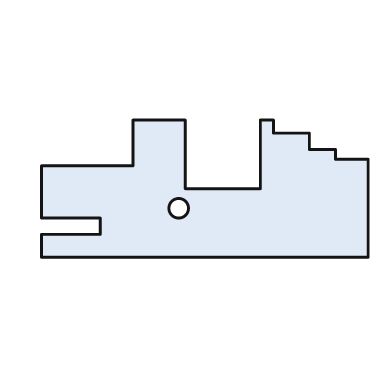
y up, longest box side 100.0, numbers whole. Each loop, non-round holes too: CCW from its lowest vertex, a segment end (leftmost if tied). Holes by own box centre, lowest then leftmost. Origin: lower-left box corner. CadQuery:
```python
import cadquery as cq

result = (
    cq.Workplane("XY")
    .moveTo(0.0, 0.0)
    .lineTo(100.0, 0.0)
    .lineTo(100.0, 30.0)
    .lineTo(90.0, 30.0)
    .lineTo(90.0, 33.0)
    .lineTo(82.0, 33.0)
    .lineTo(82.0, 38.0)
    .lineTo(71.0, 38.0)
    .lineTo(71.0, 42.0)
    .lineTo(67.0, 42.0)
    .lineTo(67.0, 21.0)
    .lineTo(44.0, 21.0)
    .lineTo(44.0, 42.0)
    .lineTo(28.0, 42.0)
    .lineTo(28.0, 28.0)
    .lineTo(0.0, 28.0)
    .lineTo(0.0, 12.0)
    .lineTo(18.0, 12.0)
    .lineTo(18.0, 7.0)
    .lineTo(0.0, 7.0)
    .close()
    .moveTo(42.0, 15.0)
    .circle(3.0)
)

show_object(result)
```